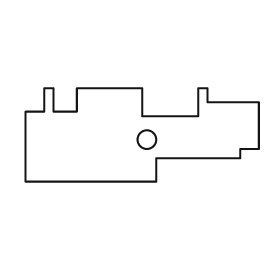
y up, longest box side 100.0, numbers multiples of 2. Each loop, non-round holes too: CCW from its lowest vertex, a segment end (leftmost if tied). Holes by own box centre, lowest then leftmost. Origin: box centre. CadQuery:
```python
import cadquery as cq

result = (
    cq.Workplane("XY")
    .moveTo(-50.0, -20.0)
    .lineTo(6.0, -20.0)
    .lineTo(6.0, -10.0)
    .lineTo(42.0, -10.0)
    .lineTo(42.0, -6.0)
    .lineTo(50.0, -6.0)
    .lineTo(50.0, 14.0)
    .lineTo(28.0, 14.0)
    .lineTo(28.0, 20.0)
    .lineTo(24.0, 20.0)
    .lineTo(24.0, 8.0)
    .lineTo(0.0, 8.0)
    .lineTo(0.0, 20.0)
    .lineTo(-28.0, 20.0)
    .lineTo(-28.0, 10.0)
    .lineTo(-38.0, 10.0)
    .lineTo(-38.0, 20.0)
    .lineTo(-42.0, 20.0)
    .lineTo(-42.0, 10.0)
    .lineTo(-50.0, 10.0)
    .close()
    .moveTo(2.0, -2.0)
    .circle(4.0)
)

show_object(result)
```